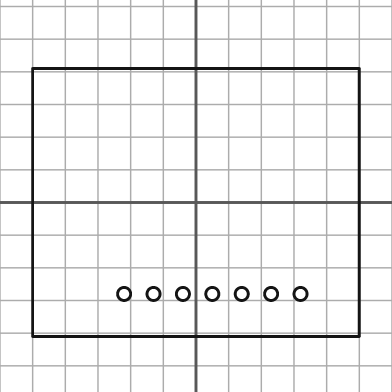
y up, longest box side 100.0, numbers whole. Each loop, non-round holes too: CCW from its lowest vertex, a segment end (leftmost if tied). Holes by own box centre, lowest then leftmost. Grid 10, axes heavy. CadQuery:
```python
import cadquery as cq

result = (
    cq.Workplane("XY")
    .moveTo(-50.0, -41.0)
    .lineTo(50.0, -41.0)
    .lineTo(50.0, 41.0)
    .lineTo(-50.0, 41.0)
    .close()
    .moveTo(-22.0, -28.0)
    .circle(2.0)
    .moveTo(-13.0, -28.0)
    .circle(2.0)
    .moveTo(-4.0, -28.0)
    .circle(2.0)
    .moveTo(5.0, -28.0)
    .circle(2.0)
    .moveTo(14.0, -28.0)
    .circle(2.0)
    .moveTo(23.0, -28.0)
    .circle(2.0)
    .moveTo(32.0, -28.0)
    .circle(2.0)
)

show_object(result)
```